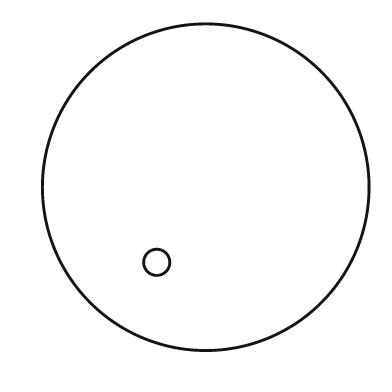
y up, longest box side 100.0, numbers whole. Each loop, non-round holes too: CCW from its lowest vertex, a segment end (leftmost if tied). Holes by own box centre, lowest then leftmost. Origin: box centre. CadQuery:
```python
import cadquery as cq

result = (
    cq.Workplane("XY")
    .moveTo(0.0, 0.0)
    .circle(50.0)
    .moveTo(-15.0, -23.0)
    .circle(4.0)
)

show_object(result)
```